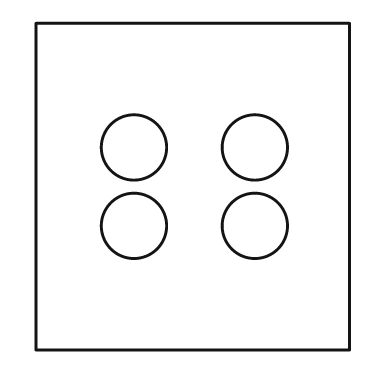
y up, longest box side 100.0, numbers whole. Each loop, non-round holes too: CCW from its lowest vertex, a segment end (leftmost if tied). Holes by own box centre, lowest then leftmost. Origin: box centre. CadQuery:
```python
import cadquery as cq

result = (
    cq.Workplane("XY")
    .moveTo(-48.0, -50.0)
    .lineTo(48.0, -50.0)
    .lineTo(48.0, 50.0)
    .lineTo(-48.0, 50.0)
    .close()
    .moveTo(-18.0, -12.0)
    .circle(10.0)
    .moveTo(19.0, -12.0)
    .circle(10.0)
    .moveTo(-18.0, 12.0)
    .circle(10.0)
    .moveTo(19.0, 12.0)
    .circle(10.0)
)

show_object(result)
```